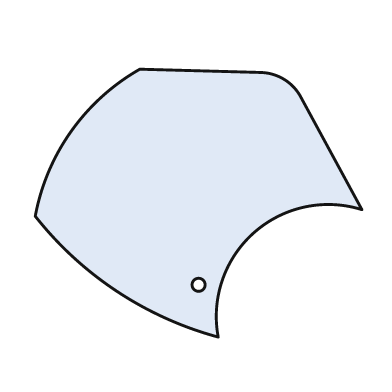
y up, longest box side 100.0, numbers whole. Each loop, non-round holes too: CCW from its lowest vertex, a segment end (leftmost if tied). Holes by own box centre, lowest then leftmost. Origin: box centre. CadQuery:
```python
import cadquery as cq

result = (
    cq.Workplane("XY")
    .moveTo(6.0, -41.0)
    .threePointArc((17.0, -9.0), (50.0, -2.0))
    .lineTo(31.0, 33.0)
    .threePointArc((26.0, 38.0), (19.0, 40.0))
    .lineTo(-18.0, 41.0)
    .threePointArc((-39.0, 22.0), (-50.0, -4.0))
    .threePointArc((-25.0, -27.0), (6.0, -41.0))
    .close()
    .moveTo(0.0, -25.0)
    .circle(2.0)
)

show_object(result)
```